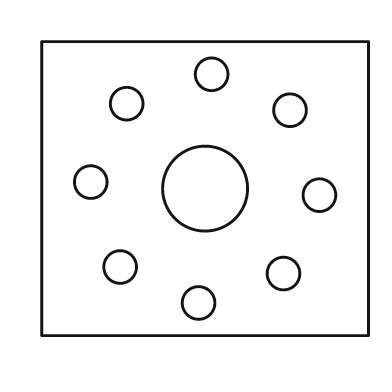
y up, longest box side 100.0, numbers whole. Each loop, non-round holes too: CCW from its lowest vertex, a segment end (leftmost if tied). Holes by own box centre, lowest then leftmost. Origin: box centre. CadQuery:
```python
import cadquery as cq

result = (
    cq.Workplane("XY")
    .moveTo(-50.0, -45.0)
    .lineTo(50.0, -45.0)
    .lineTo(50.0, 45.0)
    .lineTo(-50.0, 45.0)
    .close()
    .moveTo(-2.0, -35.0)
    .circle(5.0)
    .moveTo(24.0, -26.0)
    .circle(5.0)
    .moveTo(-26.0, -24.0)
    .circle(5.0)
    .moveTo(35.0, -2.0)
    .circle(5.0)
    .moveTo(0.0, 0.0)
    .circle(13.0)
    .moveTo(-35.0, 2.0)
    .circle(5.0)
    .moveTo(26.0, 24.0)
    .circle(5.0)
    .moveTo(-24.0, 26.0)
    .circle(5.0)
    .moveTo(2.0, 35.0)
    .circle(5.0)
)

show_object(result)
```